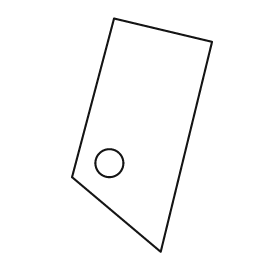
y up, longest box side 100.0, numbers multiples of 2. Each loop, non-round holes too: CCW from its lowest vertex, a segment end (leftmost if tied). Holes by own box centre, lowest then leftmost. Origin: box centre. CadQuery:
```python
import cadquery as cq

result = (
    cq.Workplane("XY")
    .moveTo(8.0, -50.0)
    .lineTo(30.0, 40.0)
    .lineTo(-12.0, 50.0)
    .lineTo(-30.0, -18.0)
    .close()
    .moveTo(-14.0, -12.0)
    .circle(6.0)
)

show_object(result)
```